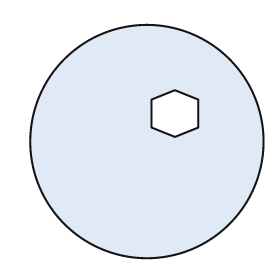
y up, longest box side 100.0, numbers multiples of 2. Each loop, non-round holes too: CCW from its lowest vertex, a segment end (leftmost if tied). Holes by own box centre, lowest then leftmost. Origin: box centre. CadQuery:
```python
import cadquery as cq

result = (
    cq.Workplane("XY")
    .moveTo(0.0, 0.0)
    .circle(50.0)
    .moveTo(12.0, 2.0)
    .lineTo(22.0, 6.0)
    .lineTo(22.0, 18.0)
    .lineTo(12.0, 22.0)
    .lineTo(2.0, 18.0)
    .lineTo(2.0, 6.0)
    .close()
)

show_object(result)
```